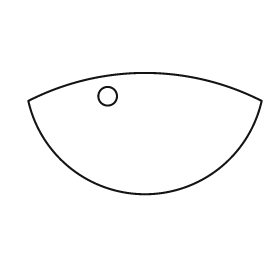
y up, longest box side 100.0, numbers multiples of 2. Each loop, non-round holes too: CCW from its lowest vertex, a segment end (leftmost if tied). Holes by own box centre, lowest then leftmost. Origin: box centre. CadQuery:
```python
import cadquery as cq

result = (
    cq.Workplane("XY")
    .moveTo(-50.0, 14.0)
    .threePointArc((0.0, -26.0), (50.0, 14.0))
    .threePointArc((0.0, 26.0), (-50.0, 14.0))
    .close()
    .moveTo(-16.0, 16.0)
    .circle(4.0)
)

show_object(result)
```